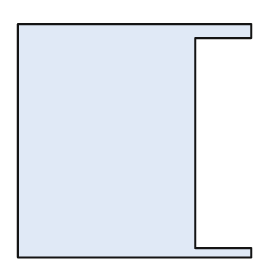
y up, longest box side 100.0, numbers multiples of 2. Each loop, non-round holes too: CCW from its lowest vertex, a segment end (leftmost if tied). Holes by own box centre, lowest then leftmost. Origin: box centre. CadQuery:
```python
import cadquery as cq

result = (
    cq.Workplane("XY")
    .moveTo(-50.0, -50.0)
    .lineTo(50.0, -50.0)
    .lineTo(50.0, -46.0)
    .lineTo(26.0, -46.0)
    .lineTo(26.0, 44.0)
    .lineTo(50.0, 44.0)
    .lineTo(50.0, 50.0)
    .lineTo(-50.0, 50.0)
    .close()
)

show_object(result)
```